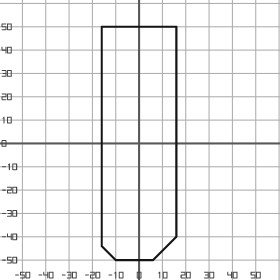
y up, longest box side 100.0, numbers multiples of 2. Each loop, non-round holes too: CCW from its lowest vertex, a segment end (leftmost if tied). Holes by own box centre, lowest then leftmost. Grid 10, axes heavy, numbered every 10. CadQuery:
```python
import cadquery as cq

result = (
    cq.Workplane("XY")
    .moveTo(-10.0, -50.0)
    .lineTo(6.0, -50.0)
    .lineTo(16.0, -40.0)
    .lineTo(16.0, 50.0)
    .lineTo(-16.0, 50.0)
    .lineTo(-16.0, -44.0)
    .close()
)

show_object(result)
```